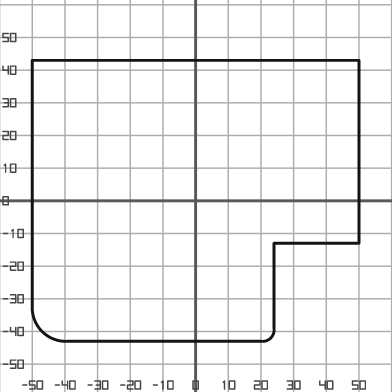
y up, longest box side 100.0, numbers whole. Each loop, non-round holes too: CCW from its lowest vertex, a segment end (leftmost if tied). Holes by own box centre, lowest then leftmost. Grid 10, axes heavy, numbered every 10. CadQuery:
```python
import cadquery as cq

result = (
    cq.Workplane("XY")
    .moveTo(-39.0, -43.0)
    .lineTo(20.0, -43.0)
    .threePointArc((23.0, -42.0), (24.0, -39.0))
    .lineTo(24.0, -13.0)
    .lineTo(50.0, -13.0)
    .lineTo(50.0, 43.0)
    .lineTo(-50.0, 43.0)
    .lineTo(-50.0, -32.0)
    .threePointArc((-47.0, -40.0), (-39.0, -43.0))
    .close()
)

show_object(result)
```